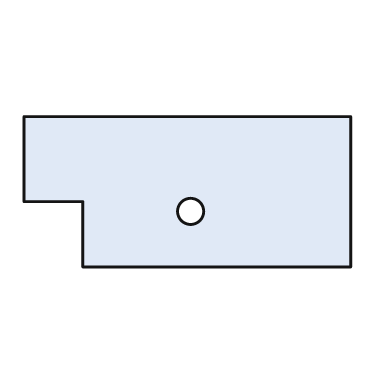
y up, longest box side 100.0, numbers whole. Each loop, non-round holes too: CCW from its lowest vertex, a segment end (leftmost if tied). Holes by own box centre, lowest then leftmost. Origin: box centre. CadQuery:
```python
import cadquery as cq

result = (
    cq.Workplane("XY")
    .moveTo(-32.0, -23.0)
    .lineTo(50.0, -23.0)
    .lineTo(50.0, 23.0)
    .lineTo(-50.0, 23.0)
    .lineTo(-50.0, -3.0)
    .lineTo(-32.0, -3.0)
    .close()
    .moveTo(1.0, -6.0)
    .circle(4.0)
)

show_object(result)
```